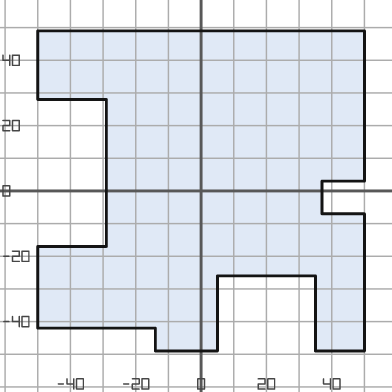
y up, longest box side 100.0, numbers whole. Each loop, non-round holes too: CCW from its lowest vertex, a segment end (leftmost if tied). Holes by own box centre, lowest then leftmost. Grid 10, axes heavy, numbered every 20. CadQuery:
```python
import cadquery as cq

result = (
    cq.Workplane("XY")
    .moveTo(-14.0, -49.0)
    .lineTo(5.0, -49.0)
    .lineTo(5.0, -26.0)
    .lineTo(35.0, -26.0)
    .lineTo(35.0, -49.0)
    .lineTo(50.0, -49.0)
    .lineTo(50.0, -7.0)
    .lineTo(37.0, -7.0)
    .lineTo(37.0, 3.0)
    .lineTo(50.0, 3.0)
    .lineTo(50.0, 49.0)
    .lineTo(-50.0, 49.0)
    .lineTo(-50.0, 28.0)
    .lineTo(-29.0, 28.0)
    .lineTo(-29.0, -17.0)
    .lineTo(-50.0, -17.0)
    .lineTo(-50.0, -42.0)
    .lineTo(-14.0, -42.0)
    .close()
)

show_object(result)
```